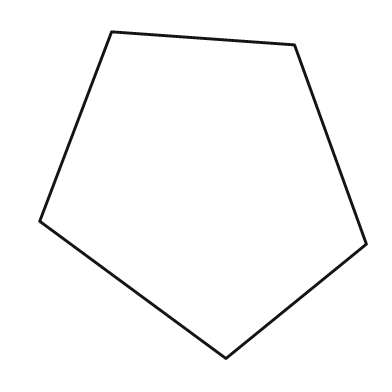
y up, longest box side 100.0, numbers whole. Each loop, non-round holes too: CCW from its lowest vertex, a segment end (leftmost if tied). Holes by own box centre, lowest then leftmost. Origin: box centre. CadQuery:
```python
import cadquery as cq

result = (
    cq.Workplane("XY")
    .moveTo(7.0, -50.0)
    .lineTo(50.0, -15.0)
    .lineTo(28.0, 46.0)
    .lineTo(-28.0, 50.0)
    .lineTo(-50.0, -8.0)
    .close()
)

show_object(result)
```